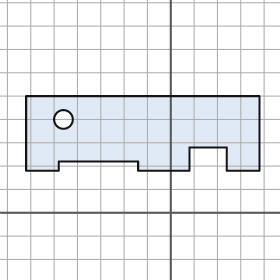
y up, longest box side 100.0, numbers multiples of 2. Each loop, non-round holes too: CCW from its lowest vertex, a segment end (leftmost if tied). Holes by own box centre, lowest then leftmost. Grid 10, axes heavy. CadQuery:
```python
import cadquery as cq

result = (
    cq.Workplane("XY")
    .moveTo(-62.0, 18.0)
    .lineTo(-48.0, 18.0)
    .lineTo(-48.0, 22.0)
    .lineTo(-14.0, 22.0)
    .lineTo(-14.0, 18.0)
    .lineTo(8.0, 18.0)
    .lineTo(8.0, 28.0)
    .lineTo(24.0, 28.0)
    .lineTo(24.0, 18.0)
    .lineTo(38.0, 18.0)
    .lineTo(38.0, 50.0)
    .lineTo(-62.0, 50.0)
    .close()
    .moveTo(-46.0, 40.0)
    .circle(4.0)
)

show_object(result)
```